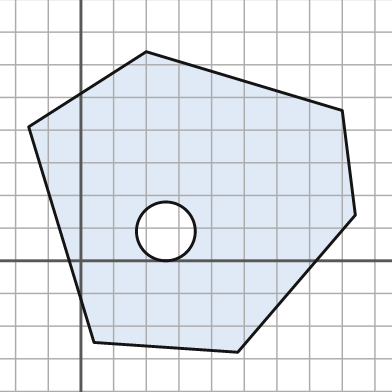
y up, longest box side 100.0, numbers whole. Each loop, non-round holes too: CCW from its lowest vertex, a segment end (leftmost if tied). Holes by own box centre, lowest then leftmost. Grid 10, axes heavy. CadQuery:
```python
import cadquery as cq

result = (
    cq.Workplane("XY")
    .moveTo(48.0, -28.0)
    .lineTo(84.0, 14.0)
    .lineTo(80.0, 46.0)
    .lineTo(20.0, 64.0)
    .lineTo(-16.0, 41.0)
    .lineTo(4.0, -25.0)
    .close()
    .moveTo(26.0, 9.0)
    .circle(9.0)
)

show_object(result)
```